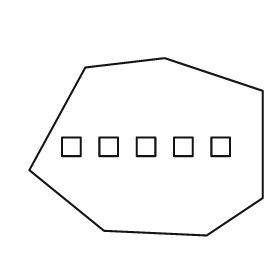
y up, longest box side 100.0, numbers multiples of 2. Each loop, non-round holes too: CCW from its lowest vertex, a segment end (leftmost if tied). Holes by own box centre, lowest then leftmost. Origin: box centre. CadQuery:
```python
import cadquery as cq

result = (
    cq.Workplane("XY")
    .moveTo(26.0, -38.0)
    .lineTo(50.0, -22.0)
    .lineTo(50.0, 24.0)
    .lineTo(8.0, 38.0)
    .lineTo(-26.0, 34.0)
    .lineTo(-50.0, -10.0)
    .lineTo(-18.0, -36.0)
    .close()
    .moveTo(-36.0, -4.0)
    .lineTo(-28.0, -4.0)
    .lineTo(-28.0, 4.0)
    .lineTo(-36.0, 4.0)
    .close()
    .moveTo(-20.0, -4.0)
    .lineTo(-12.0, -4.0)
    .lineTo(-12.0, 4.0)
    .lineTo(-20.0, 4.0)
    .close()
    .moveTo(-4.0, -4.0)
    .lineTo(4.0, -4.0)
    .lineTo(4.0, 4.0)
    .lineTo(-4.0, 4.0)
    .close()
    .moveTo(12.0, -4.0)
    .lineTo(20.0, -4.0)
    .lineTo(20.0, 4.0)
    .lineTo(12.0, 4.0)
    .close()
    .moveTo(28.0, -4.0)
    .lineTo(36.0, -4.0)
    .lineTo(36.0, 4.0)
    .lineTo(28.0, 4.0)
    .close()
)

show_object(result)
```